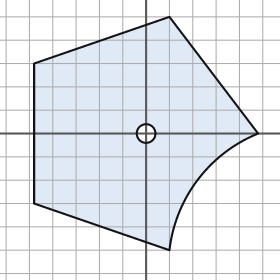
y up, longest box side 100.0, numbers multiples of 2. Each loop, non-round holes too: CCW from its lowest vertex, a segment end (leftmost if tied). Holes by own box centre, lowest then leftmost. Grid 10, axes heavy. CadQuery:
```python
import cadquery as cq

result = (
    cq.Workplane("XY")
    .moveTo(10.0, -50.0)
    .threePointArc((22.0, -20.0), (48.0, 0.0))
    .lineTo(10.0, 50.0)
    .lineTo(-48.0, 30.0)
    .lineTo(-48.0, -30.0)
    .close()
    .moveTo(0.0, 0.0)
    .circle(4.0)
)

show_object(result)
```